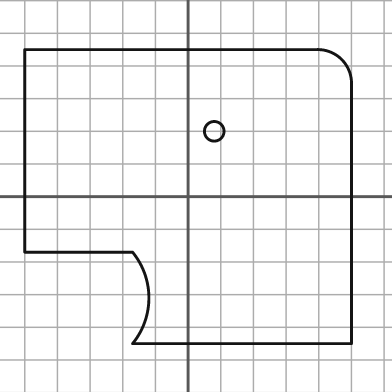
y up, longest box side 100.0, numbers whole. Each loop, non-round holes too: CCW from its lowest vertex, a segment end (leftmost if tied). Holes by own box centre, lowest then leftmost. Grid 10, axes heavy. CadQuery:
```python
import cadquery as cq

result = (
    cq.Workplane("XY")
    .moveTo(-17.0, -45.0)
    .lineTo(50.0, -45.0)
    .lineTo(50.0, 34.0)
    .threePointArc((47.0, 42.0), (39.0, 45.0))
    .lineTo(-50.0, 45.0)
    .lineTo(-50.0, -17.0)
    .lineTo(-17.0, -17.0)
    .threePointArc((-12.0, -31.0), (-17.0, -45.0))
    .close()
    .moveTo(8.0, 20.0)
    .circle(3.0)
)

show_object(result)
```